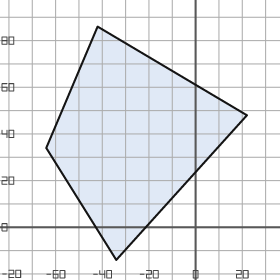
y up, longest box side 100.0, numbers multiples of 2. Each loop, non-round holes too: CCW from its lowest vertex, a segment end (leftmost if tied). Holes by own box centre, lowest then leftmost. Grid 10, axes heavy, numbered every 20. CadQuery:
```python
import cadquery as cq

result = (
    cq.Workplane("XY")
    .moveTo(-34.0, -14.0)
    .lineTo(22.0, 48.0)
    .lineTo(-42.0, 86.0)
    .lineTo(-64.0, 34.0)
    .close()
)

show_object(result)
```